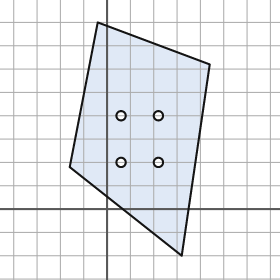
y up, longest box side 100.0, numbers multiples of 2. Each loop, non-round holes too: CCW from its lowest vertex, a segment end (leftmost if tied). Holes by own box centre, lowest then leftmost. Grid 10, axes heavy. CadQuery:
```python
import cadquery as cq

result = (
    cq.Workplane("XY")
    .moveTo(32.0, -20.0)
    .lineTo(44.0, 62.0)
    .lineTo(-4.0, 80.0)
    .lineTo(-16.0, 18.0)
    .close()
    .moveTo(6.0, 20.0)
    .circle(2.0)
    .moveTo(22.0, 20.0)
    .circle(2.0)
    .moveTo(6.0, 40.0)
    .circle(2.0)
    .moveTo(22.0, 40.0)
    .circle(2.0)
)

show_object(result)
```